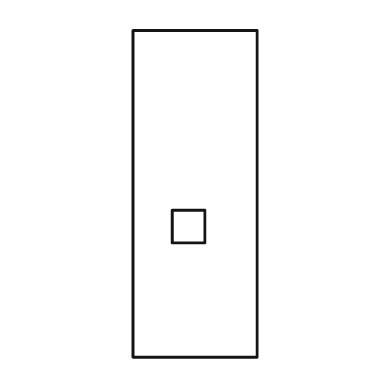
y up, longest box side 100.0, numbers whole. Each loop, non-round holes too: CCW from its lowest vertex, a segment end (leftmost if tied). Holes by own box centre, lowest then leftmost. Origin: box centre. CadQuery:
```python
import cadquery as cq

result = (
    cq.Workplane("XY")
    .moveTo(-19.0, -50.0)
    .lineTo(19.0, -50.0)
    .lineTo(19.0, 50.0)
    .lineTo(-19.0, 50.0)
    .close()
    .moveTo(-7.0, -15.0)
    .lineTo(3.0, -15.0)
    .lineTo(3.0, -5.0)
    .lineTo(-7.0, -5.0)
    .close()
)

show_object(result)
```